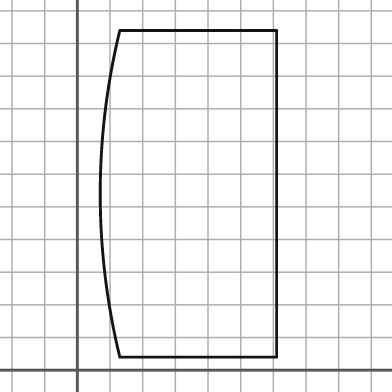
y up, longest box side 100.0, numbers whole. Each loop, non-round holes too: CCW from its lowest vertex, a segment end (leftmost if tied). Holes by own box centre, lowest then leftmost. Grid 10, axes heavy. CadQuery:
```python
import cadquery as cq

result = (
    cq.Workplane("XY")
    .moveTo(13.0, 4.0)
    .lineTo(61.0, 4.0)
    .lineTo(61.0, 104.0)
    .lineTo(13.0, 104.0)
    .threePointArc((7.0, 54.0), (13.0, 4.0))
    .close()
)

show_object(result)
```